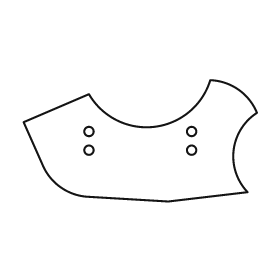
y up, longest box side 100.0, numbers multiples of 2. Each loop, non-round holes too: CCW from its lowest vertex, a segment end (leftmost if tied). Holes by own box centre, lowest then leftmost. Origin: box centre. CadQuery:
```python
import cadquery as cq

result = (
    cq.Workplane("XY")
    .moveTo(12.0, -26.0)
    .lineTo(46.0, -22.0)
    .threePointArc((40.0, -4.0), (50.0, 12.0))
    .threePointArc((42.0, 22.0), (30.0, 26.0))
    .threePointArc((6.0, 6.0), (-22.0, 20.0))
    .lineTo(-50.0, 8.0)
    .lineTo(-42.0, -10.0)
    .threePointArc((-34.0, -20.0), (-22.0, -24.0))
    .close()
    .moveTo(-22.0, -4.0)
    .circle(2.0)
    .moveTo(22.0, -4.0)
    .circle(2.0)
    .moveTo(-22.0, 4.0)
    .circle(2.0)
    .moveTo(22.0, 4.0)
    .circle(2.0)
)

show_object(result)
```